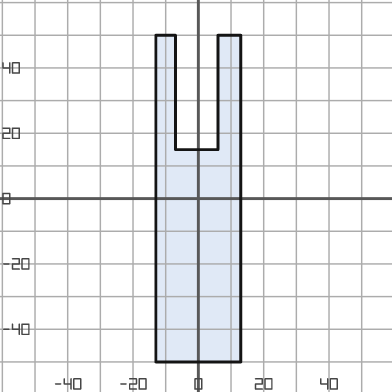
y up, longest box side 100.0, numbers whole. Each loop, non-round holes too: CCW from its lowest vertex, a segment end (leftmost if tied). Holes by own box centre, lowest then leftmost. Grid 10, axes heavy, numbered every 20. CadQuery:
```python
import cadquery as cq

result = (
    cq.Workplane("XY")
    .moveTo(-13.0, -50.0)
    .lineTo(13.0, -50.0)
    .lineTo(13.0, 50.0)
    .lineTo(6.0, 50.0)
    .lineTo(6.0, 15.0)
    .lineTo(-7.0, 15.0)
    .lineTo(-7.0, 50.0)
    .lineTo(-13.0, 50.0)
    .close()
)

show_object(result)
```